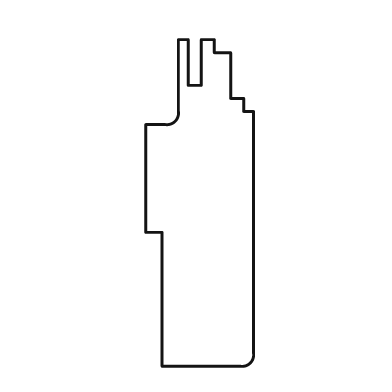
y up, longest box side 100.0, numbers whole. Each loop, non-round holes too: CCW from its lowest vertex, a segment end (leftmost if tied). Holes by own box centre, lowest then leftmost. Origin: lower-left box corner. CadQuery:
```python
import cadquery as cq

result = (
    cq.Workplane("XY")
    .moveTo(5.0, 0.0)
    .lineTo(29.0, 0.0)
    .threePointArc((32.0, 1.0), (33.0, 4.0))
    .lineTo(33.0, 78.0)
    .lineTo(30.0, 78.0)
    .lineTo(30.0, 82.0)
    .lineTo(26.0, 82.0)
    .lineTo(26.0, 96.0)
    .lineTo(21.0, 96.0)
    .lineTo(21.0, 100.0)
    .lineTo(17.0, 100.0)
    .lineTo(17.0, 86.0)
    .lineTo(13.0, 86.0)
    .lineTo(13.0, 100.0)
    .lineTo(10.0, 100.0)
    .lineTo(10.0, 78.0)
    .threePointArc((9.0, 75.0), (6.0, 74.0))
    .lineTo(0.0, 74.0)
    .lineTo(0.0, 41.0)
    .lineTo(5.0, 41.0)
    .close()
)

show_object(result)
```